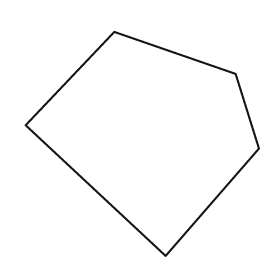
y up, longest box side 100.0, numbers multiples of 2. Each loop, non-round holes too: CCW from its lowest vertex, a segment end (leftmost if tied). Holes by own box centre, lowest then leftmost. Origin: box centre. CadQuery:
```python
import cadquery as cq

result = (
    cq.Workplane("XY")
    .moveTo(10.0, -48.0)
    .lineTo(50.0, -2.0)
    .lineTo(40.0, 30.0)
    .lineTo(-12.0, 48.0)
    .lineTo(-50.0, 8.0)
    .close()
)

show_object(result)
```